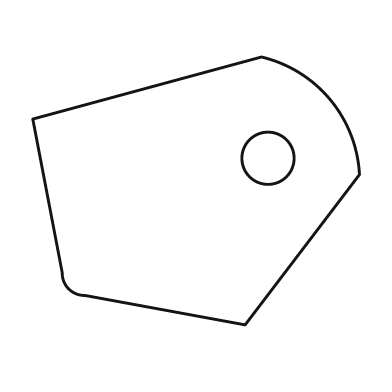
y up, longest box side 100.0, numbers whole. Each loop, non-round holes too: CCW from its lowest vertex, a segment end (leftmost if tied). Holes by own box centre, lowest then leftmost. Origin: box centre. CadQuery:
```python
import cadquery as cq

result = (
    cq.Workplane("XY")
    .moveTo(15.0, -41.0)
    .lineTo(50.0, 5.0)
    .threePointArc((41.0, 28.0), (20.0, 41.0))
    .lineTo(-50.0, 22.0)
    .lineTo(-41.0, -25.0)
    .threePointArc((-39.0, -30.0), (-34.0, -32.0))
    .close()
    .moveTo(22.0, 10.0)
    .circle(8.0)
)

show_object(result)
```